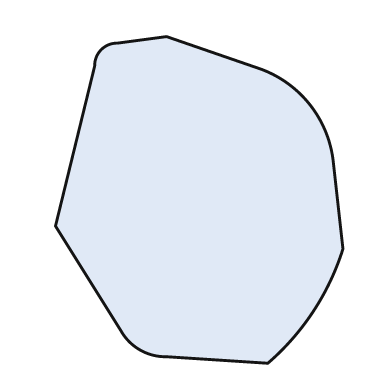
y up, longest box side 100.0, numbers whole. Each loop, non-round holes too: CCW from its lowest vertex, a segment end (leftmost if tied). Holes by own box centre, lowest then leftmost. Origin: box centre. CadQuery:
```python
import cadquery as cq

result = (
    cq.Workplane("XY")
    .moveTo(21.0, -50.0)
    .threePointArc((35.0, -34.0), (44.0, -15.0))
    .lineTo(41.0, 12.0)
    .threePointArc((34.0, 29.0), (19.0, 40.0))
    .lineTo(-10.0, 50.0)
    .lineTo(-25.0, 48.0)
    .threePointArc((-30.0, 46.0), (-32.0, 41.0))
    .lineTo(-44.0, -8.0)
    .lineTo(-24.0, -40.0)
    .threePointArc((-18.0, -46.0), (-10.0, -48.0))
    .close()
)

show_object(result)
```